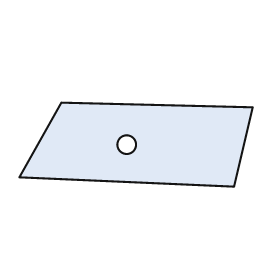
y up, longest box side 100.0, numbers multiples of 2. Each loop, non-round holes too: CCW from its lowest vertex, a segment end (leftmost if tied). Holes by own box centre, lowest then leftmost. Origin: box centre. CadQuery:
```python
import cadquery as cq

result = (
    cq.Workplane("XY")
    .moveTo(42.0, -18.0)
    .lineTo(50.0, 16.0)
    .lineTo(-32.0, 18.0)
    .lineTo(-50.0, -14.0)
    .close()
    .moveTo(-4.0, 0.0)
    .circle(4.0)
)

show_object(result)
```